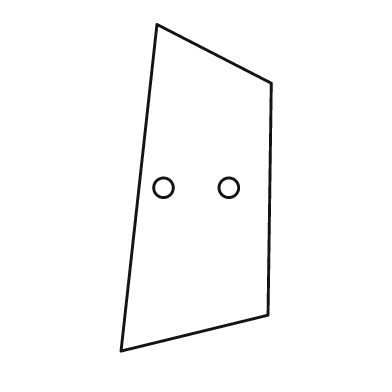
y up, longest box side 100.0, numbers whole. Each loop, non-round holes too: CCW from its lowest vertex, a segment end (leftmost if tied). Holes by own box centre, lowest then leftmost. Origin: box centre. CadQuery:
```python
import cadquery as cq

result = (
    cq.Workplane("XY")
    .moveTo(-23.0, -50.0)
    .lineTo(22.0, -39.0)
    .lineTo(23.0, 32.0)
    .lineTo(-12.0, 50.0)
    .close()
    .moveTo(-10.0, 0.0)
    .circle(3.0)
    .moveTo(10.0, 0.0)
    .circle(3.0)
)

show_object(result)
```